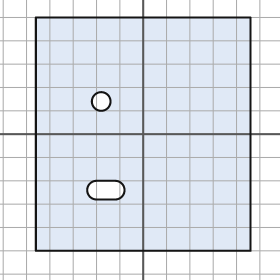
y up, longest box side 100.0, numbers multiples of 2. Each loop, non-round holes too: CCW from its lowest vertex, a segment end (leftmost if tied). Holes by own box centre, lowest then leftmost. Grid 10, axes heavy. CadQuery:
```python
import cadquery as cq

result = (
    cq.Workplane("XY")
    .moveTo(-46.0, -50.0)
    .lineTo(46.0, -50.0)
    .lineTo(46.0, 50.0)
    .lineTo(-46.0, 50.0)
    .close()
    .moveTo(-20.0, -28.0)
    .lineTo(-12.0, -28.0)
    .threePointArc((-8.0, -24.0), (-12.0, -20.0))
    .lineTo(-20.0, -20.0)
    .threePointArc((-24.0, -24.0), (-20.0, -28.0))
    .close()
    .moveTo(-18.0, 14.0)
    .circle(4.0)
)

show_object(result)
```